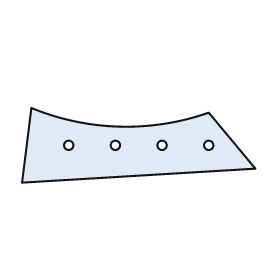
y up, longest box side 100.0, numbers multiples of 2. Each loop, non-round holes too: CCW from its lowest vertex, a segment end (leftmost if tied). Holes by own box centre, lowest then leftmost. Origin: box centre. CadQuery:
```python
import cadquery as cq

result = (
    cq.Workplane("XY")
    .moveTo(-50.0, -16.0)
    .lineTo(50.0, -10.0)
    .lineTo(30.0, 14.0)
    .threePointArc((-8.0, 8.0), (-46.0, 16.0))
    .close()
    .moveTo(-30.0, 0.0)
    .circle(2.0)
    .moveTo(-10.0, 0.0)
    .circle(2.0)
    .moveTo(10.0, 0.0)
    .circle(2.0)
    .moveTo(30.0, 0.0)
    .circle(2.0)
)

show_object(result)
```